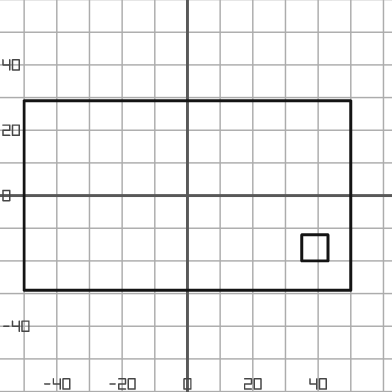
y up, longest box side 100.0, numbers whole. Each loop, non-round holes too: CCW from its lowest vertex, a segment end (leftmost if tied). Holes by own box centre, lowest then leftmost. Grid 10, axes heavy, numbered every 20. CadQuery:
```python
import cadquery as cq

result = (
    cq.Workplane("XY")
    .moveTo(-50.0, -29.0)
    .lineTo(50.0, -29.0)
    .lineTo(50.0, 29.0)
    .lineTo(-50.0, 29.0)
    .close()
    .moveTo(35.0, -20.0)
    .lineTo(43.0, -20.0)
    .lineTo(43.0, -12.0)
    .lineTo(35.0, -12.0)
    .close()
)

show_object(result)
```